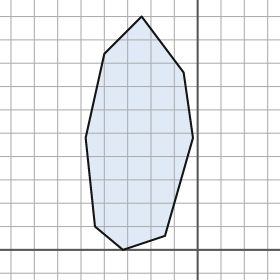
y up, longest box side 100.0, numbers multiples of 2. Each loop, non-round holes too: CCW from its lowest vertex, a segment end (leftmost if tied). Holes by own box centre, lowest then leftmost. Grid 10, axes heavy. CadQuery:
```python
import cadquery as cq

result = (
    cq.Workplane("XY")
    .moveTo(-32.0, 0.0)
    .lineTo(-14.0, 6.0)
    .lineTo(-2.0, 48.0)
    .lineTo(-6.0, 76.0)
    .lineTo(-24.0, 100.0)
    .lineTo(-40.0, 84.0)
    .lineTo(-48.0, 48.0)
    .lineTo(-44.0, 10.0)
    .close()
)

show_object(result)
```